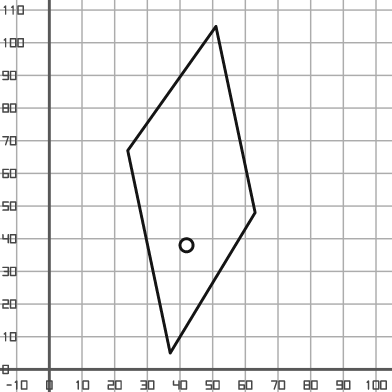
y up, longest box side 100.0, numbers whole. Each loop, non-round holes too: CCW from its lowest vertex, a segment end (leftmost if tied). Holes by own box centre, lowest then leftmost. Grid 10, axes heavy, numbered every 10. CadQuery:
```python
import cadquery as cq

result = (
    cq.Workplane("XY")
    .moveTo(37.0, 5.0)
    .lineTo(63.0, 48.0)
    .lineTo(51.0, 105.0)
    .lineTo(24.0, 67.0)
    .close()
    .moveTo(42.0, 38.0)
    .circle(2.0)
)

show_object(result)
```